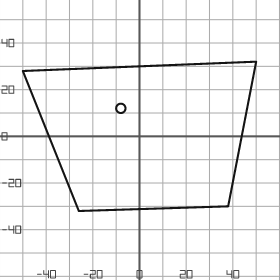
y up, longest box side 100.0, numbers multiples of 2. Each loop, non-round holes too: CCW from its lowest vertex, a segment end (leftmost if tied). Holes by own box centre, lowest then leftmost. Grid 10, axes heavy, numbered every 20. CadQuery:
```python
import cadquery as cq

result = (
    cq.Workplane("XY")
    .moveTo(-26.0, -32.0)
    .lineTo(38.0, -30.0)
    .lineTo(50.0, 32.0)
    .lineTo(-50.0, 28.0)
    .close()
    .moveTo(-8.0, 12.0)
    .circle(2.0)
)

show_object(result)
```